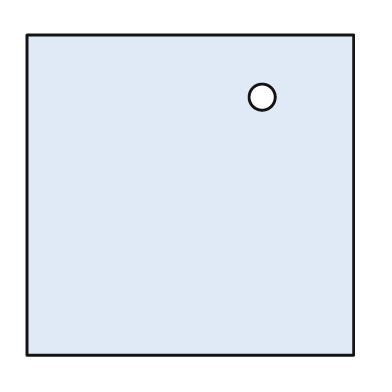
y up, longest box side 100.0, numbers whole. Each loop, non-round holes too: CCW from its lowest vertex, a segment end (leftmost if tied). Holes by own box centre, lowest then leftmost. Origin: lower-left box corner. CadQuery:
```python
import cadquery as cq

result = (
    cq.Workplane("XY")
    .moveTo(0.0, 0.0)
    .lineTo(100.0, 0.0)
    .lineTo(100.0, 98.0)
    .lineTo(0.0, 98.0)
    .close()
    .moveTo(72.0, 79.0)
    .circle(4.0)
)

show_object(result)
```